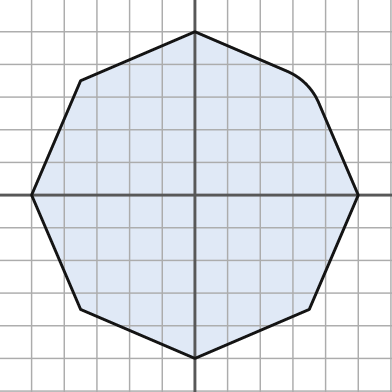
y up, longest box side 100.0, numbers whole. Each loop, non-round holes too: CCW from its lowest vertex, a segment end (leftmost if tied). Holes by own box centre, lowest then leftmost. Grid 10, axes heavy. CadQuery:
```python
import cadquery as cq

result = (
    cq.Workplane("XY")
    .moveTo(0.0, -50.0)
    .lineTo(35.0, -35.0)
    .lineTo(50.0, 0.0)
    .lineTo(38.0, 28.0)
    .threePointArc((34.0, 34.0), (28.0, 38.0))
    .lineTo(0.0, 50.0)
    .lineTo(-35.0, 35.0)
    .lineTo(-50.0, 0.0)
    .lineTo(-35.0, -35.0)
    .close()
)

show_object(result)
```